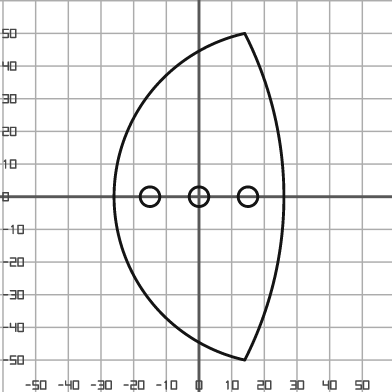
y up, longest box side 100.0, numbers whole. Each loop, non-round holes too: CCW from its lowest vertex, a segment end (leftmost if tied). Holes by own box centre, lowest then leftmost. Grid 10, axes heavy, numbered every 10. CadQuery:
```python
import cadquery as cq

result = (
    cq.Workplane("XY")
    .moveTo(14.0, -50.0)
    .threePointArc((26.0, 0.0), (14.0, 50.0))
    .threePointArc((-26.0, 0.0), (14.0, -50.0))
    .close()
    .moveTo(-15.0, 0.0)
    .circle(3.0)
    .moveTo(0.0, 0.0)
    .circle(3.0)
    .moveTo(15.0, 0.0)
    .circle(3.0)
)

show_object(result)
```